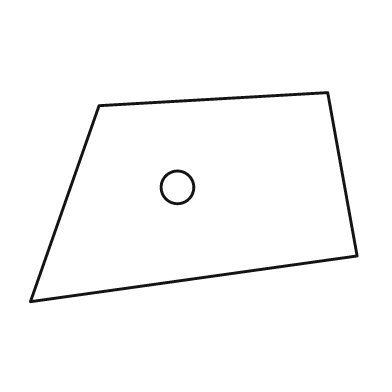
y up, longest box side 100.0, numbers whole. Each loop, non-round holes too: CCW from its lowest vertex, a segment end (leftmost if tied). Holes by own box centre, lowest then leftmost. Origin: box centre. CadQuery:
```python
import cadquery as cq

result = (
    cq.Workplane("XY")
    .moveTo(-50.0, -32.0)
    .lineTo(50.0, -18.0)
    .lineTo(41.0, 32.0)
    .lineTo(-29.0, 28.0)
    .close()
    .moveTo(-5.0, 3.0)
    .circle(5.0)
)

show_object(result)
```